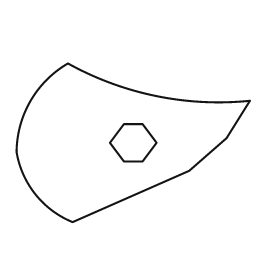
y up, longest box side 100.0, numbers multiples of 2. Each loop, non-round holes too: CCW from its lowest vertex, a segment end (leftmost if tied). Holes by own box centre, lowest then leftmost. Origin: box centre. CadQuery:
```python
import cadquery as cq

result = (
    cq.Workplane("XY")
    .moveTo(-26.0, -34.0)
    .lineTo(24.0, -12.0)
    .lineTo(40.0, 2.0)
    .lineTo(50.0, 18.0)
    .threePointArc((10.0, 20.0), (-28.0, 34.0))
    .threePointArc((-44.0, 18.0), (-50.0, -4.0))
    .threePointArc((-42.0, -22.0), (-26.0, -34.0))
    .close()
    .moveTo(-4.0, -8.0)
    .lineTo(4.0, -8.0)
    .lineTo(10.0, 0.0)
    .lineTo(4.0, 8.0)
    .lineTo(-4.0, 8.0)
    .lineTo(-10.0, 0.0)
    .close()
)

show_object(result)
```